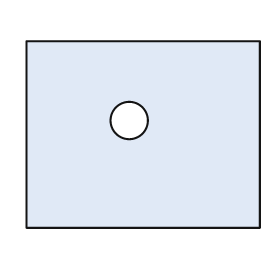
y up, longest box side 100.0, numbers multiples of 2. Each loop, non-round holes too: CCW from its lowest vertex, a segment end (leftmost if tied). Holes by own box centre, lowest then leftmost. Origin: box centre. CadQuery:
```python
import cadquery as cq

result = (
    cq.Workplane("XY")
    .moveTo(-50.0, -40.0)
    .lineTo(50.0, -40.0)
    .lineTo(50.0, 40.0)
    .lineTo(-50.0, 40.0)
    .close()
    .moveTo(-6.0, 6.0)
    .circle(8.0)
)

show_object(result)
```